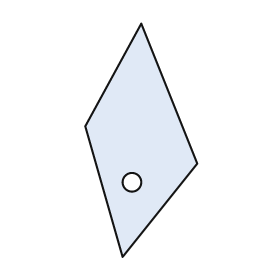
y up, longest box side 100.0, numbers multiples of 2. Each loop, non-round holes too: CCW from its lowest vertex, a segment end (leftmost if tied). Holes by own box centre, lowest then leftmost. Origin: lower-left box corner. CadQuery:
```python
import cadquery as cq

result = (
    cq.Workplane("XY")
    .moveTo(16.0, 0.0)
    .lineTo(48.0, 40.0)
    .lineTo(24.0, 100.0)
    .lineTo(0.0, 56.0)
    .close()
    .moveTo(20.0, 32.0)
    .circle(4.0)
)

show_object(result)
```